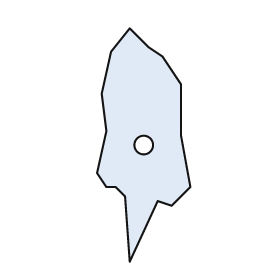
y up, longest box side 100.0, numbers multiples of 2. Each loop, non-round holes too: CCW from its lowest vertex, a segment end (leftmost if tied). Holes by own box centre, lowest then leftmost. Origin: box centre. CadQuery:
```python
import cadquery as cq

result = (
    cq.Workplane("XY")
    .moveTo(-6.0, -50.0)
    .lineTo(6.0, -24.0)
    .lineTo(12.0, -26.0)
    .lineTo(20.0, -18.0)
    .lineTo(16.0, 4.0)
    .lineTo(16.0, 26.0)
    .lineTo(8.0, 38.0)
    .lineTo(2.0, 42.0)
    .lineTo(-6.0, 50.0)
    .lineTo(-14.0, 40.0)
    .lineTo(-18.0, 22.0)
    .lineTo(-16.0, 6.0)
    .lineTo(-20.0, -12.0)
    .lineTo(-16.0, -18.0)
    .lineTo(-12.0, -18.0)
    .lineTo(-8.0, -22.0)
    .close()
    .moveTo(0.0, 0.0)
    .circle(4.0)
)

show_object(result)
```